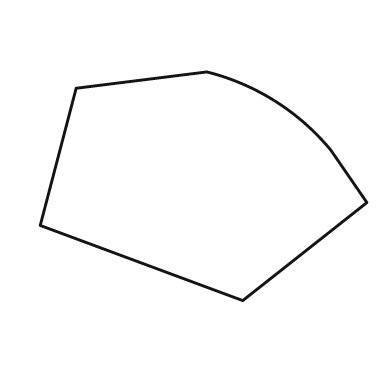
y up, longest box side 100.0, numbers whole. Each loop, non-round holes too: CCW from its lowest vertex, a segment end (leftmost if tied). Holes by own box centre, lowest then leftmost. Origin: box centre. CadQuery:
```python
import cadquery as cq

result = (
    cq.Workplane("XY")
    .moveTo(12.0, -35.0)
    .lineTo(50.0, -5.0)
    .lineTo(39.0, 11.0)
    .threePointArc((22.0, 26.0), (1.0, 35.0))
    .lineTo(-39.0, 30.0)
    .lineTo(-50.0, -12.0)
    .close()
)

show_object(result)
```